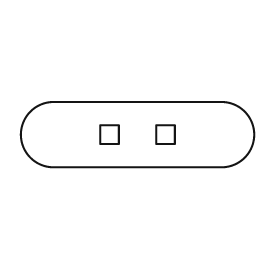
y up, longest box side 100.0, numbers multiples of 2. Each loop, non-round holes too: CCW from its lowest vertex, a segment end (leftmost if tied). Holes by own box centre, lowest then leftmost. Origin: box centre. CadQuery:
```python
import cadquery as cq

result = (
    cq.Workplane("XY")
    .moveTo(-36.0, -14.0)
    .lineTo(36.0, -14.0)
    .threePointArc((50.0, 0.0), (36.0, 14.0))
    .lineTo(-36.0, 14.0)
    .threePointArc((-50.0, 0.0), (-36.0, -14.0))
    .close()
    .moveTo(-16.0, -4.0)
    .lineTo(-8.0, -4.0)
    .lineTo(-8.0, 4.0)
    .lineTo(-16.0, 4.0)
    .close()
    .moveTo(8.0, -4.0)
    .lineTo(16.0, -4.0)
    .lineTo(16.0, 4.0)
    .lineTo(8.0, 4.0)
    .close()
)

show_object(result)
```